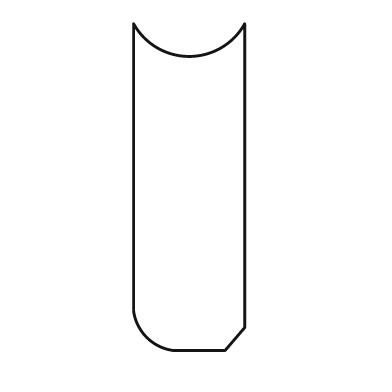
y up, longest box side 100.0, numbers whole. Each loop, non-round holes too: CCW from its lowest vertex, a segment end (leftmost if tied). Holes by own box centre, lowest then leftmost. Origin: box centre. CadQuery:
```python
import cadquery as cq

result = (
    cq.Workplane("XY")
    .moveTo(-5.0, -50.0)
    .lineTo(11.0, -50.0)
    .lineTo(17.0, -43.0)
    .lineTo(17.0, 50.0)
    .threePointArc((0.0, 40.0), (-17.0, 50.0))
    .lineTo(-17.0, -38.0)
    .threePointArc((-13.0, -46.0), (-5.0, -50.0))
    .close()
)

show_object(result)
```